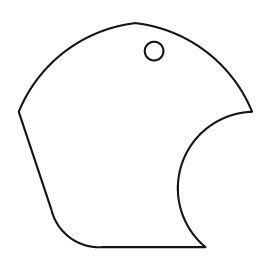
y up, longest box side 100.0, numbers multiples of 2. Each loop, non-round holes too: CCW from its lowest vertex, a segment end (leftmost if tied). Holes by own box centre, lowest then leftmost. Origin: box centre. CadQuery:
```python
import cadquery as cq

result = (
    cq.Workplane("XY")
    .moveTo(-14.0, -48.0)
    .lineTo(30.0, -48.0)
    .threePointArc((20.0, -12.0), (50.0, 10.0))
    .threePointArc((30.0, 36.0), (0.0, 48.0))
    .threePointArc((-30.0, 36.0), (-50.0, 10.0))
    .lineTo(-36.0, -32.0)
    .threePointArc((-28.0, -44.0), (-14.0, -48.0))
    .close()
    .moveTo(8.0, 36.0)
    .circle(4.0)
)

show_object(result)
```